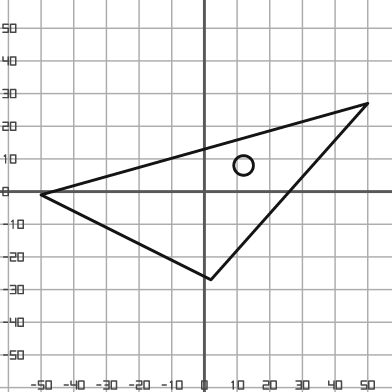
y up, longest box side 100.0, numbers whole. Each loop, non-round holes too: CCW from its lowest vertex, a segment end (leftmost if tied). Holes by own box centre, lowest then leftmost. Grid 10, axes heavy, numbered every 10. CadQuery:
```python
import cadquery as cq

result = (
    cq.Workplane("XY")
    .moveTo(2.0, -27.0)
    .lineTo(50.0, 27.0)
    .lineTo(-50.0, -1.0)
    .close()
    .moveTo(12.0, 8.0)
    .circle(3.0)
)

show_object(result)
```